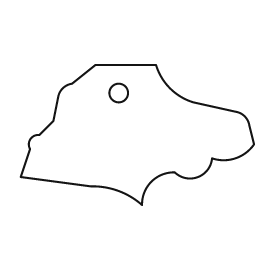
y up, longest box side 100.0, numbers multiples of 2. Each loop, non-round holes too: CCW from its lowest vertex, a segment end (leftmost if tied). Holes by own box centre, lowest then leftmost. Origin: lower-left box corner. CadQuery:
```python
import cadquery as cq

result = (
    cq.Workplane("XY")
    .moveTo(52.0, 0.0)
    .threePointArc((56.0, 10.0), (66.0, 14.0))
    .threePointArc((76.0, 12.0), (82.0, 20.0))
    .threePointArc((92.0, 20.0), (100.0, 26.0))
    .lineTo(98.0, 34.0)
    .threePointArc((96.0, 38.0), (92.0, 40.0))
    .lineTo(74.0, 44.0)
    .threePointArc((64.0, 50.0), (58.0, 60.0))
    .lineTo(32.0, 60.0)
    .lineTo(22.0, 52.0)
    .threePointArc((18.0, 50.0), (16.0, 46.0))
    .lineTo(14.0, 36.0)
    .lineTo(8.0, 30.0)
    .threePointArc((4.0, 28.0), (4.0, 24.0))
    .lineTo(0.0, 12.0)
    .lineTo(30.0, 8.0)
    .threePointArc((42.0, 6.0), (52.0, 0.0))
    .close()
    .moveTo(42.0, 48.0)
    .circle(4.0)
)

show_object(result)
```